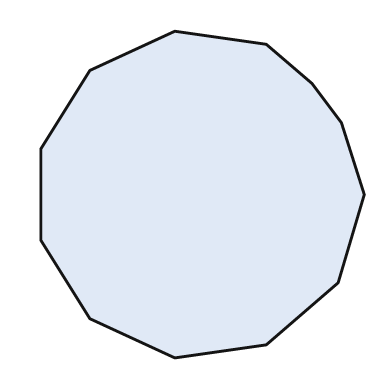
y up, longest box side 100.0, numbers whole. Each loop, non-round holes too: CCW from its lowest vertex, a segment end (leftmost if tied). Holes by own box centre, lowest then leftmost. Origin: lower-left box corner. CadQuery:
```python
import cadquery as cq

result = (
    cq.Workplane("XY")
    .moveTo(41.0, 0.0)
    .lineTo(69.0, 4.0)
    .lineTo(91.0, 23.0)
    .lineTo(99.0, 50.0)
    .lineTo(92.0, 72.0)
    .lineTo(83.0, 84.0)
    .lineTo(69.0, 96.0)
    .lineTo(41.0, 100.0)
    .lineTo(15.0, 88.0)
    .lineTo(0.0, 64.0)
    .lineTo(0.0, 36.0)
    .lineTo(15.0, 12.0)
    .close()
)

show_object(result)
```